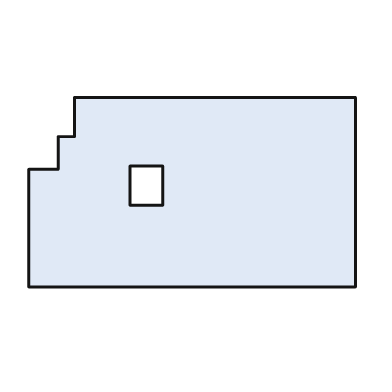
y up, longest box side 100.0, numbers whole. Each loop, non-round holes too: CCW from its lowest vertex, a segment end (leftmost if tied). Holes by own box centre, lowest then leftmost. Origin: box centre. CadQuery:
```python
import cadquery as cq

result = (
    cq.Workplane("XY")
    .moveTo(-50.0, -29.0)
    .lineTo(50.0, -29.0)
    .lineTo(50.0, 29.0)
    .lineTo(-36.0, 29.0)
    .lineTo(-36.0, 17.0)
    .lineTo(-41.0, 17.0)
    .lineTo(-41.0, 7.0)
    .lineTo(-50.0, 7.0)
    .close()
    .moveTo(-19.0, -4.0)
    .lineTo(-9.0, -4.0)
    .lineTo(-9.0, 8.0)
    .lineTo(-19.0, 8.0)
    .close()
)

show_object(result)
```